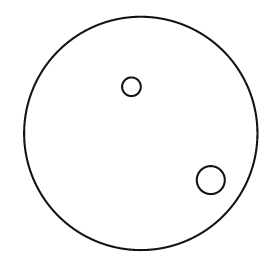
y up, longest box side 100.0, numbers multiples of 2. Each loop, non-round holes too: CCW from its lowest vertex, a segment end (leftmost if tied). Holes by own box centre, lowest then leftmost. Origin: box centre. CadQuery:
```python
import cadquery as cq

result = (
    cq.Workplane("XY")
    .moveTo(0.0, 0.0)
    .circle(50.0)
    .moveTo(30.0, -20.0)
    .circle(6.0)
    .moveTo(-4.0, 20.0)
    .circle(4.0)
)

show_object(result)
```